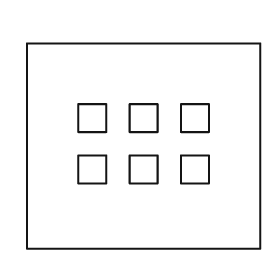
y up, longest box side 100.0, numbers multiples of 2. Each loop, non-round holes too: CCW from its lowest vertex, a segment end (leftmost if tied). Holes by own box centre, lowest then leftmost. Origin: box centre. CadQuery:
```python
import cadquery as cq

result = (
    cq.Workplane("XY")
    .moveTo(-50.0, -44.0)
    .lineTo(50.0, -44.0)
    .lineTo(50.0, 44.0)
    .lineTo(-50.0, 44.0)
    .close()
    .moveTo(-28.0, -16.0)
    .lineTo(-16.0, -16.0)
    .lineTo(-16.0, -4.0)
    .lineTo(-28.0, -4.0)
    .close()
    .moveTo(-6.0, -16.0)
    .lineTo(6.0, -16.0)
    .lineTo(6.0, -4.0)
    .lineTo(-6.0, -4.0)
    .close()
    .moveTo(16.0, -16.0)
    .lineTo(28.0, -16.0)
    .lineTo(28.0, -4.0)
    .lineTo(16.0, -4.0)
    .close()
    .moveTo(-28.0, 6.0)
    .lineTo(-16.0, 6.0)
    .lineTo(-16.0, 18.0)
    .lineTo(-28.0, 18.0)
    .close()
    .moveTo(-6.0, 6.0)
    .lineTo(6.0, 6.0)
    .lineTo(6.0, 18.0)
    .lineTo(-6.0, 18.0)
    .close()
    .moveTo(16.0, 6.0)
    .lineTo(28.0, 6.0)
    .lineTo(28.0, 18.0)
    .lineTo(16.0, 18.0)
    .close()
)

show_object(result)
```